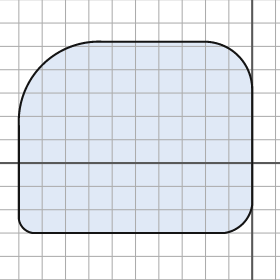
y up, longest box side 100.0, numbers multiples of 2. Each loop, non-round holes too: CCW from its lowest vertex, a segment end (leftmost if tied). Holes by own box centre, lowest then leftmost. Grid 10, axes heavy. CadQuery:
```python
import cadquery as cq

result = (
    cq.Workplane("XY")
    .moveTo(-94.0, -30.0)
    .lineTo(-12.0, -30.0)
    .threePointArc((-4.0, -26.0), (0.0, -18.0))
    .lineTo(0.0, 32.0)
    .threePointArc((-6.0, 46.0), (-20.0, 52.0))
    .lineTo(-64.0, 52.0)
    .threePointArc((-90.0, 42.0), (-100.0, 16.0))
    .lineTo(-100.0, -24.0)
    .threePointArc((-98.0, -28.0), (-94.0, -30.0))
    .close()
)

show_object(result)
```